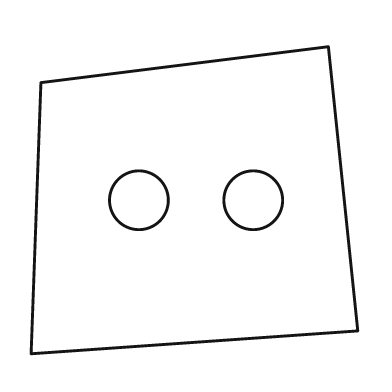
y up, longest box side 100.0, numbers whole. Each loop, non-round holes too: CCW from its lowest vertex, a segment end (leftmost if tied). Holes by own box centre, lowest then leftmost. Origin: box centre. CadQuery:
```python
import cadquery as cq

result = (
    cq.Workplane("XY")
    .moveTo(-50.0, -47.0)
    .lineTo(50.0, -40.0)
    .lineTo(41.0, 47.0)
    .lineTo(-47.0, 36.0)
    .close()
    .moveTo(-17.0, 0.0)
    .circle(9.0)
    .moveTo(18.0, 0.0)
    .circle(9.0)
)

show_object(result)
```